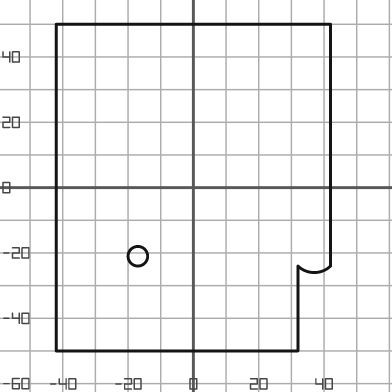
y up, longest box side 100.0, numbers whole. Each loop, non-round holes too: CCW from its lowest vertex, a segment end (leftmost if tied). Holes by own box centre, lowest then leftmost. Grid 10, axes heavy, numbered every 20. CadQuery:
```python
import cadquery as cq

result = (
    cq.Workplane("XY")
    .moveTo(-42.0, -50.0)
    .lineTo(32.0, -50.0)
    .lineTo(32.0, -24.0)
    .threePointArc((37.0, -26.0), (42.0, -24.0))
    .lineTo(42.0, 50.0)
    .lineTo(-42.0, 50.0)
    .close()
    .moveTo(-17.0, -21.0)
    .circle(3.0)
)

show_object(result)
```